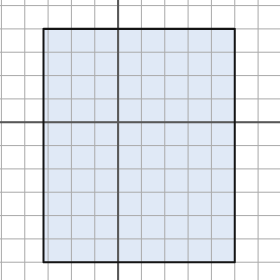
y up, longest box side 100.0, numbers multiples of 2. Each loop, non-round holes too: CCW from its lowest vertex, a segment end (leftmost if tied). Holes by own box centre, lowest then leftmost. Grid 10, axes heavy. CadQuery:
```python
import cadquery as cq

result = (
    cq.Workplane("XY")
    .moveTo(-32.0, -60.0)
    .lineTo(50.0, -60.0)
    .lineTo(50.0, 40.0)
    .lineTo(-32.0, 40.0)
    .close()
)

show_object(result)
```